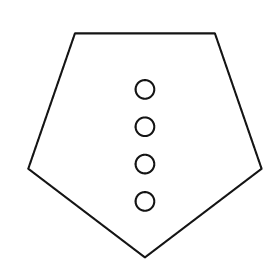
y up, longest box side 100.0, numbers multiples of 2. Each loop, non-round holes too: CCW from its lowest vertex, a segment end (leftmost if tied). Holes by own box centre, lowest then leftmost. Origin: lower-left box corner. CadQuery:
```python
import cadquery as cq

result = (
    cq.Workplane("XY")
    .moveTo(50.0, 0.0)
    .lineTo(100.0, 38.0)
    .lineTo(80.0, 96.0)
    .lineTo(20.0, 96.0)
    .lineTo(0.0, 38.0)
    .close()
    .moveTo(50.0, 24.0)
    .circle(4.0)
    .moveTo(50.0, 40.0)
    .circle(4.0)
    .moveTo(50.0, 56.0)
    .circle(4.0)
    .moveTo(50.0, 72.0)
    .circle(4.0)
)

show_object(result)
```